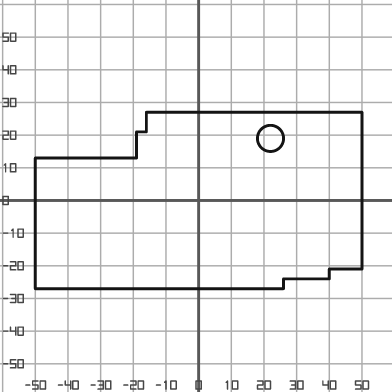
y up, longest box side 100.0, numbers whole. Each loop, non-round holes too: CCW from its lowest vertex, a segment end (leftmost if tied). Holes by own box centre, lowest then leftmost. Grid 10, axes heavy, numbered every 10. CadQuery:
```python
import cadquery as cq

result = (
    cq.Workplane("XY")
    .moveTo(-50.0, -27.0)
    .lineTo(26.0, -27.0)
    .lineTo(26.0, -24.0)
    .lineTo(40.0, -24.0)
    .lineTo(40.0, -21.0)
    .lineTo(50.0, -21.0)
    .lineTo(50.0, 27.0)
    .lineTo(-16.0, 27.0)
    .lineTo(-16.0, 21.0)
    .lineTo(-19.0, 21.0)
    .lineTo(-19.0, 13.0)
    .lineTo(-50.0, 13.0)
    .close()
    .moveTo(22.0, 19.0)
    .circle(4.0)
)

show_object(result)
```